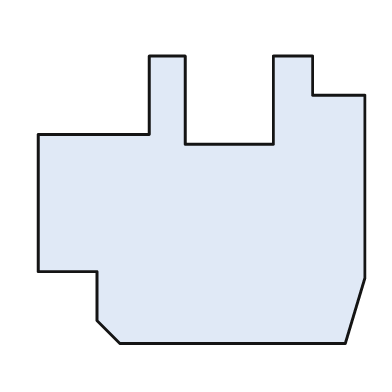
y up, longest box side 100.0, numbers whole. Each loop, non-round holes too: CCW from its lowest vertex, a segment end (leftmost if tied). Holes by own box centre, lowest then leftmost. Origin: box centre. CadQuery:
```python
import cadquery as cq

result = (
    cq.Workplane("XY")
    .moveTo(-25.0, -44.0)
    .lineTo(44.0, -44.0)
    .lineTo(50.0, -24.0)
    .lineTo(50.0, 32.0)
    .lineTo(34.0, 32.0)
    .lineTo(34.0, 44.0)
    .lineTo(22.0, 44.0)
    .lineTo(22.0, 17.0)
    .lineTo(-5.0, 17.0)
    .lineTo(-5.0, 44.0)
    .lineTo(-16.0, 44.0)
    .lineTo(-16.0, 20.0)
    .lineTo(-50.0, 20.0)
    .lineTo(-50.0, -22.0)
    .lineTo(-32.0, -22.0)
    .lineTo(-32.0, -37.0)
    .close()
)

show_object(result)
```